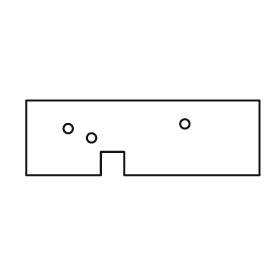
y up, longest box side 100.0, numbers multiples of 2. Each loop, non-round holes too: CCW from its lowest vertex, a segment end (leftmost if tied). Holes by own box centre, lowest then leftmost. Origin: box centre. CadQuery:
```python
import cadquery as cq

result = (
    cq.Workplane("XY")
    .moveTo(-50.0, -16.0)
    .lineTo(-18.0, -16.0)
    .lineTo(-18.0, -6.0)
    .lineTo(-8.0, -6.0)
    .lineTo(-8.0, -16.0)
    .lineTo(50.0, -16.0)
    .lineTo(50.0, 16.0)
    .lineTo(-50.0, 16.0)
    .close()
    .moveTo(-22.0, 0.0)
    .circle(2.0)
    .moveTo(-32.0, 4.0)
    .circle(2.0)
    .moveTo(18.0, 6.0)
    .circle(2.0)
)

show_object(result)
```